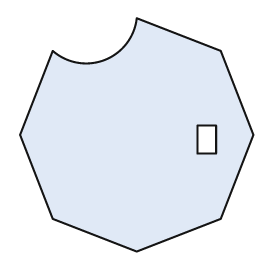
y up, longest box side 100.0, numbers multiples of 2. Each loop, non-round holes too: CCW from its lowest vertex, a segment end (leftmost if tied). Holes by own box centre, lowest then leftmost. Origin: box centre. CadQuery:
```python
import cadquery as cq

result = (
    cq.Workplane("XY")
    .moveTo(0.0, -50.0)
    .lineTo(36.0, -36.0)
    .lineTo(50.0, 0.0)
    .lineTo(36.0, 36.0)
    .lineTo(0.0, 50.0)
    .threePointArc((-14.0, 32.0), (-36.0, 36.0))
    .lineTo(-50.0, 0.0)
    .lineTo(-36.0, -36.0)
    .close()
    .moveTo(26.0, -8.0)
    .lineTo(34.0, -8.0)
    .lineTo(34.0, 4.0)
    .lineTo(26.0, 4.0)
    .close()
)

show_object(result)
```